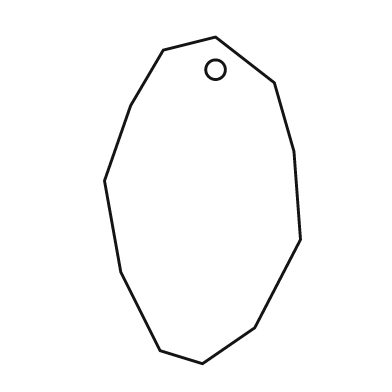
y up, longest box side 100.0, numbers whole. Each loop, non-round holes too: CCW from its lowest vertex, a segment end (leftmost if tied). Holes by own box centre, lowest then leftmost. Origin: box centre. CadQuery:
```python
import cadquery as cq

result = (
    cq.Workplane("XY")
    .moveTo(0.0, -50.0)
    .lineTo(16.0, -39.0)
    .lineTo(30.0, -12.0)
    .lineTo(28.0, 15.0)
    .lineTo(22.0, 36.0)
    .lineTo(4.0, 50.0)
    .lineTo(-12.0, 46.0)
    .lineTo(-22.0, 29.0)
    .lineTo(-30.0, 6.0)
    .lineTo(-25.0, -22.0)
    .lineTo(-13.0, -46.0)
    .close()
    .moveTo(4.0, 40.0)
    .circle(3.0)
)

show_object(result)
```